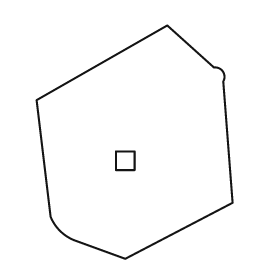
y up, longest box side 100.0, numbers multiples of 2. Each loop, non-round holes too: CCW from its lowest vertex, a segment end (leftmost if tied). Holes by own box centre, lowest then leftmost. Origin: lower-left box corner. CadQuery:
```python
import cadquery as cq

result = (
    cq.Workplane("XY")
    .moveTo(38.0, 0.0)
    .lineTo(84.0, 24.0)
    .lineTo(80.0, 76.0)
    .threePointArc((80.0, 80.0), (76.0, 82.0))
    .lineTo(56.0, 100.0)
    .lineTo(0.0, 68.0)
    .lineTo(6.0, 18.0)
    .threePointArc((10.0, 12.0), (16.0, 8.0))
    .close()
    .moveTo(34.0, 38.0)
    .lineTo(42.0, 38.0)
    .lineTo(42.0, 46.0)
    .lineTo(34.0, 46.0)
    .close()
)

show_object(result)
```